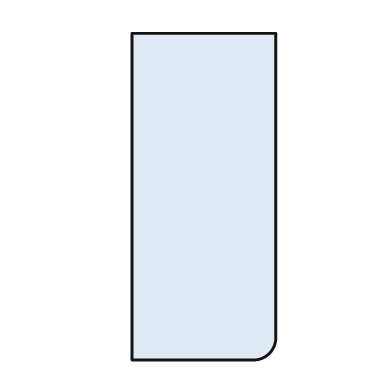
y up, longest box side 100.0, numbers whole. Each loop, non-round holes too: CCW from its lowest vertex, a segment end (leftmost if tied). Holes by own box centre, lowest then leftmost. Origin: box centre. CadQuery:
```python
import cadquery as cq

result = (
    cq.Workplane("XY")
    .moveTo(-22.0, -50.0)
    .lineTo(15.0, -50.0)
    .threePointArc((20.0, -48.0), (22.0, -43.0))
    .lineTo(22.0, 50.0)
    .lineTo(-22.0, 50.0)
    .close()
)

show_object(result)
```